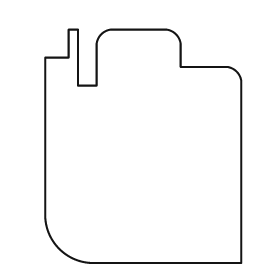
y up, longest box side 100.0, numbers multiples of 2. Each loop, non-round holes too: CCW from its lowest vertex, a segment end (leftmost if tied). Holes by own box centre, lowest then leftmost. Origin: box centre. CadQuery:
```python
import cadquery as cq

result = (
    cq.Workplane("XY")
    .moveTo(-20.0, -50.0)
    .lineTo(42.0, -50.0)
    .lineTo(42.0, 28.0)
    .threePointArc((40.0, 32.0), (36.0, 34.0))
    .lineTo(16.0, 34.0)
    .lineTo(16.0, 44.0)
    .threePointArc((14.0, 48.0), (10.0, 50.0))
    .lineTo(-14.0, 50.0)
    .threePointArc((-18.0, 48.0), (-20.0, 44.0))
    .lineTo(-20.0, 26.0)
    .lineTo(-28.0, 26.0)
    .lineTo(-28.0, 50.0)
    .lineTo(-32.0, 50.0)
    .lineTo(-32.0, 38.0)
    .lineTo(-42.0, 38.0)
    .lineTo(-42.0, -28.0)
    .threePointArc((-36.0, -44.0), (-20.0, -50.0))
    .close()
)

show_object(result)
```